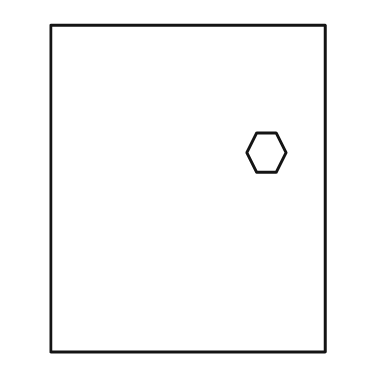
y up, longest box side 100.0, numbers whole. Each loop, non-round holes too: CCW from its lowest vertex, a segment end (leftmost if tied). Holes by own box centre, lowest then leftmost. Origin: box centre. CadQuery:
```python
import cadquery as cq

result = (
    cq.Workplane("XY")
    .moveTo(-42.0, -50.0)
    .lineTo(42.0, -50.0)
    .lineTo(42.0, 50.0)
    .lineTo(-42.0, 50.0)
    .close()
    .moveTo(21.0, 5.0)
    .lineTo(27.0, 5.0)
    .lineTo(30.0, 11.0)
    .lineTo(27.0, 17.0)
    .lineTo(21.0, 17.0)
    .lineTo(18.0, 11.0)
    .close()
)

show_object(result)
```